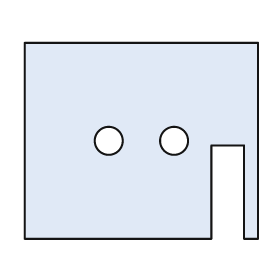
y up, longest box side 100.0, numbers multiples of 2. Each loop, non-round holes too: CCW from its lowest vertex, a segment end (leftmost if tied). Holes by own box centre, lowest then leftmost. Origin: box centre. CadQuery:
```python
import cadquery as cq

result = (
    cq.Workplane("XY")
    .moveTo(-50.0, -42.0)
    .lineTo(30.0, -42.0)
    .lineTo(30.0, -2.0)
    .lineTo(44.0, -2.0)
    .lineTo(44.0, -42.0)
    .lineTo(50.0, -42.0)
    .lineTo(50.0, 42.0)
    .lineTo(-50.0, 42.0)
    .close()
    .moveTo(-14.0, 0.0)
    .circle(6.0)
    .moveTo(14.0, 0.0)
    .circle(6.0)
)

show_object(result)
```